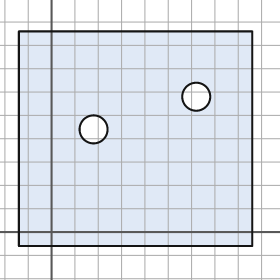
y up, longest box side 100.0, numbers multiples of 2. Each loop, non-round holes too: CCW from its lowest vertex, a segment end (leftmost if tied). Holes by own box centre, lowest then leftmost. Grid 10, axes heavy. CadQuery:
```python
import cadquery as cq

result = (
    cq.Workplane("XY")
    .moveTo(-14.0, -6.0)
    .lineTo(86.0, -6.0)
    .lineTo(86.0, 86.0)
    .lineTo(-14.0, 86.0)
    .close()
    .moveTo(18.0, 44.0)
    .circle(6.0)
    .moveTo(62.0, 58.0)
    .circle(6.0)
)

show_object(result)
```